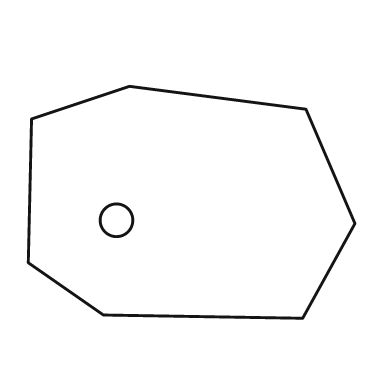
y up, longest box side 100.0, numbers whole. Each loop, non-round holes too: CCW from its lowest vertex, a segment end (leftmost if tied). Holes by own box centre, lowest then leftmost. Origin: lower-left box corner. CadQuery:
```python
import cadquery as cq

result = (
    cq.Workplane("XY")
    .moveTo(84.0, 0.0)
    .lineTo(100.0, 29.0)
    .lineTo(85.0, 64.0)
    .lineTo(31.0, 71.0)
    .lineTo(1.0, 61.0)
    .lineTo(0.0, 17.0)
    .lineTo(23.0, 1.0)
    .close()
    .moveTo(27.0, 30.0)
    .circle(5.0)
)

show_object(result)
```